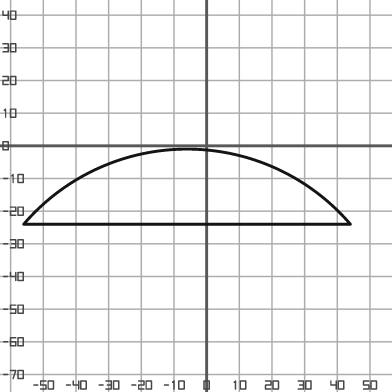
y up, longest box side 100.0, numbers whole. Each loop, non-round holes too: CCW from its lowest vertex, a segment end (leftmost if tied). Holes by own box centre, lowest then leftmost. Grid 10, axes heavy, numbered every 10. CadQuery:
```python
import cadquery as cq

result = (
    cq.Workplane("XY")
    .moveTo(-56.0, -24.0)
    .lineTo(44.0, -24.0)
    .threePointArc((-6.0, -1.0), (-56.0, -24.0))
    .close()
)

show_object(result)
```